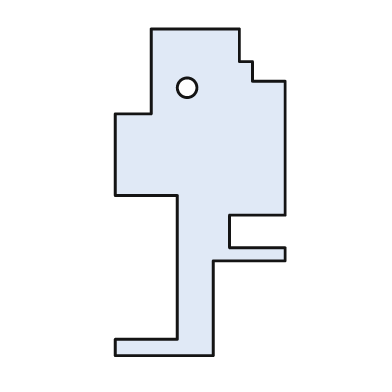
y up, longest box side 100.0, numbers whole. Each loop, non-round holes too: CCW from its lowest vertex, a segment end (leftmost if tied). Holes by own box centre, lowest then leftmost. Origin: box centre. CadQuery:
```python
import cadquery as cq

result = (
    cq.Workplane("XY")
    .moveTo(-26.0, -50.0)
    .lineTo(4.0, -50.0)
    .lineTo(4.0, -21.0)
    .lineTo(26.0, -21.0)
    .lineTo(26.0, -17.0)
    .lineTo(9.0, -17.0)
    .lineTo(9.0, -7.0)
    .lineTo(26.0, -7.0)
    .lineTo(26.0, 34.0)
    .lineTo(16.0, 34.0)
    .lineTo(16.0, 40.0)
    .lineTo(12.0, 40.0)
    .lineTo(12.0, 50.0)
    .lineTo(-15.0, 50.0)
    .lineTo(-15.0, 24.0)
    .lineTo(-26.0, 24.0)
    .lineTo(-26.0, -1.0)
    .lineTo(-7.0, -1.0)
    .lineTo(-7.0, -45.0)
    .lineTo(-26.0, -45.0)
    .close()
    .moveTo(-4.0, 32.0)
    .circle(3.0)
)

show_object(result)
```